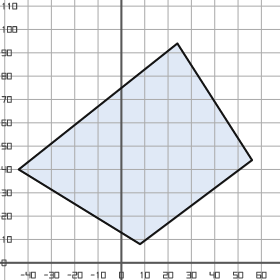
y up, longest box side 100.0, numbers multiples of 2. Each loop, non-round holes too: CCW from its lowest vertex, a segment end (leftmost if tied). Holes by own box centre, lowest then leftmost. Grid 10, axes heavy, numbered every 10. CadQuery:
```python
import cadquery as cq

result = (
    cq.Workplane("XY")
    .moveTo(8.0, 8.0)
    .lineTo(56.0, 44.0)
    .lineTo(24.0, 94.0)
    .lineTo(-44.0, 40.0)
    .close()
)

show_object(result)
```